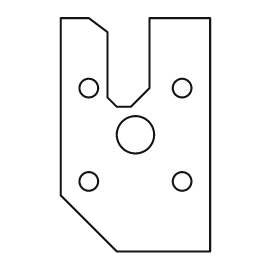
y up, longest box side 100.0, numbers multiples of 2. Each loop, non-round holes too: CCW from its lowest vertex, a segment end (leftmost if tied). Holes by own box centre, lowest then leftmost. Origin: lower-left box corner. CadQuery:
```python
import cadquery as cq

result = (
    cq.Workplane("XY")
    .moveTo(24.0, 0.0)
    .lineTo(64.0, 0.0)
    .lineTo(64.0, 100.0)
    .lineTo(38.0, 100.0)
    .lineTo(38.0, 70.0)
    .lineTo(30.0, 62.0)
    .lineTo(24.0, 62.0)
    .lineTo(20.0, 66.0)
    .lineTo(20.0, 94.0)
    .lineTo(12.0, 100.0)
    .lineTo(0.0, 100.0)
    .lineTo(0.0, 24.0)
    .close()
    .moveTo(12.0, 30.0)
    .circle(4.0)
    .moveTo(52.0, 30.0)
    .circle(4.0)
    .moveTo(32.0, 50.0)
    .circle(8.0)
    .moveTo(12.0, 70.0)
    .circle(4.0)
    .moveTo(52.0, 70.0)
    .circle(4.0)
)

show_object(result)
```